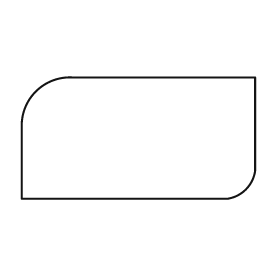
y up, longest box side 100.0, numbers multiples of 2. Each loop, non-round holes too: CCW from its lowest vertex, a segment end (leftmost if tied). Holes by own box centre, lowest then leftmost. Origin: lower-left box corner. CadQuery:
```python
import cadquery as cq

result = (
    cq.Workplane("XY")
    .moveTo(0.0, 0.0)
    .lineTo(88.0, 0.0)
    .threePointArc((96.0, 4.0), (100.0, 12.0))
    .lineTo(100.0, 52.0)
    .lineTo(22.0, 52.0)
    .threePointArc((6.0, 46.0), (0.0, 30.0))
    .close()
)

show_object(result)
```